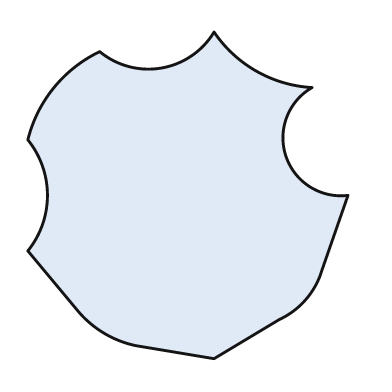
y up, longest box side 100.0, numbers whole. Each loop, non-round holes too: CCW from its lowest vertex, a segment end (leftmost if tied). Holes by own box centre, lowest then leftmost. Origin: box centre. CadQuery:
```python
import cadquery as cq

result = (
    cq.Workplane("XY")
    .moveTo(8.0, -50.0)
    .lineTo(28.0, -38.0)
    .threePointArc((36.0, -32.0), (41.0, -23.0))
    .lineTo(49.0, 0.0)
    .threePointArc((30.0, 12.0), (38.0, 33.0))
    .threePointArc((21.0, 38.0), (8.0, 50.0))
    .threePointArc((-8.0, 39.0), (-27.0, 44.0))
    .threePointArc((-41.0, 33.0), (-49.0, 17.0))
    .threePointArc((-43.0, 0.0), (-49.0, -17.0))
    .lineTo(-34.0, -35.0)
    .threePointArc((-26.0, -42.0), (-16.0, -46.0))
    .close()
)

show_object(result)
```